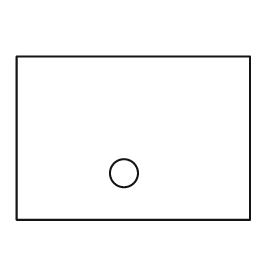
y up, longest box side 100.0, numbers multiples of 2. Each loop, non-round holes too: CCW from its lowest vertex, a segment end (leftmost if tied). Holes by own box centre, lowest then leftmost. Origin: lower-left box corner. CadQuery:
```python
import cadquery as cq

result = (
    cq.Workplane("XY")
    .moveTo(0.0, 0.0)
    .lineTo(100.0, 0.0)
    .lineTo(100.0, 70.0)
    .lineTo(0.0, 70.0)
    .close()
    .moveTo(46.0, 20.0)
    .circle(6.0)
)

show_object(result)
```